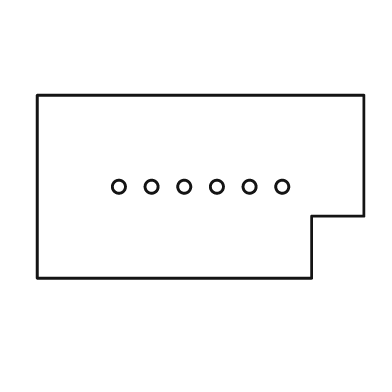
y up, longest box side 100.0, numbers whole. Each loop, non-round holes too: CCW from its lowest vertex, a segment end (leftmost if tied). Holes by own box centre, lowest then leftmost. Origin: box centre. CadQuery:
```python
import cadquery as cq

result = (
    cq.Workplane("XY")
    .moveTo(-50.0, -28.0)
    .lineTo(34.0, -28.0)
    .lineTo(34.0, -9.0)
    .lineTo(50.0, -9.0)
    .lineTo(50.0, 28.0)
    .lineTo(-50.0, 28.0)
    .close()
    .moveTo(-25.0, 0.0)
    .circle(2.0)
    .moveTo(-15.0, 0.0)
    .circle(2.0)
    .moveTo(-5.0, 0.0)
    .circle(2.0)
    .moveTo(5.0, 0.0)
    .circle(2.0)
    .moveTo(15.0, 0.0)
    .circle(2.0)
    .moveTo(25.0, 0.0)
    .circle(2.0)
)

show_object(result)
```